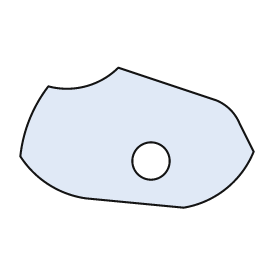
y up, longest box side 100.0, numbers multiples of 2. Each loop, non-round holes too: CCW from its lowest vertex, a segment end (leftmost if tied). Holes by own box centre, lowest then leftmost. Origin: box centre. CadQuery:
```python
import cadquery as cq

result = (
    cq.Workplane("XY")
    .moveTo(20.0, -30.0)
    .threePointArc((38.0, -22.0), (50.0, -6.0))
    .lineTo(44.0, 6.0)
    .threePointArc((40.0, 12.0), (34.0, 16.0))
    .lineTo(-8.0, 30.0)
    .threePointArc((-22.0, 22.0), (-38.0, 22.0))
    .threePointArc((-46.0, 8.0), (-50.0, -8.0))
    .threePointArc((-38.0, -20.0), (-22.0, -26.0))
    .close()
    .moveTo(6.0, -10.0)
    .circle(8.0)
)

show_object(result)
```